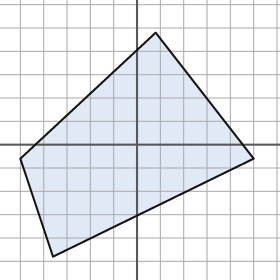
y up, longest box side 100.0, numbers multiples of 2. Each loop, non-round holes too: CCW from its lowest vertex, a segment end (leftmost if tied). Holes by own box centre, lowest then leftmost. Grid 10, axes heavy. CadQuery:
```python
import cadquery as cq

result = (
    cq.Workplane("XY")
    .moveTo(-36.0, -48.0)
    .lineTo(50.0, -6.0)
    .lineTo(8.0, 48.0)
    .lineTo(-50.0, -6.0)
    .close()
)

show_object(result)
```